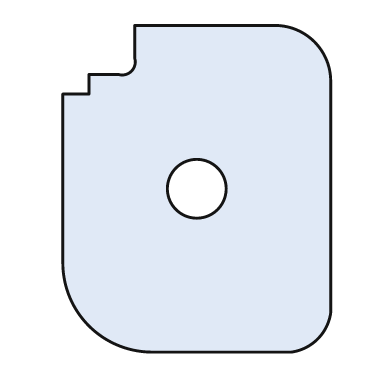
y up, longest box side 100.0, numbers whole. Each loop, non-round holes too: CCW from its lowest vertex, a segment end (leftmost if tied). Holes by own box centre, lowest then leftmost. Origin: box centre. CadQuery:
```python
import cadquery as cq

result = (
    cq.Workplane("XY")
    .moveTo(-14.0, -50.0)
    .lineTo(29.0, -50.0)
    .threePointArc((37.0, -46.0), (41.0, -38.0))
    .lineTo(41.0, 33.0)
    .threePointArc((36.0, 45.0), (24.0, 50.0))
    .lineTo(-19.0, 50.0)
    .lineTo(-19.0, 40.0)
    .threePointArc((-20.0, 36.0), (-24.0, 35.0))
    .lineTo(-33.0, 35.0)
    .lineTo(-33.0, 29.0)
    .lineTo(-41.0, 29.0)
    .lineTo(-41.0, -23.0)
    .threePointArc((-33.0, -42.0), (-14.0, -50.0))
    .close()
    .moveTo(0.0, 0.0)
    .circle(9.0)
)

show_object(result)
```